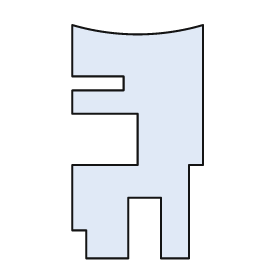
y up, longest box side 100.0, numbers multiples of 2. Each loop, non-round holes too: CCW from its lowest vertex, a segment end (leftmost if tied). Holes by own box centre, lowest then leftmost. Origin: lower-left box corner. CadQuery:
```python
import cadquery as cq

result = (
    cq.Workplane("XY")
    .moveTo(6.0, 0.0)
    .lineTo(24.0, 0.0)
    .lineTo(24.0, 26.0)
    .lineTo(38.0, 26.0)
    .lineTo(38.0, 0.0)
    .lineTo(50.0, 0.0)
    .lineTo(50.0, 40.0)
    .lineTo(56.0, 40.0)
    .lineTo(56.0, 100.0)
    .threePointArc((28.0, 96.0), (0.0, 100.0))
    .lineTo(0.0, 78.0)
    .lineTo(22.0, 78.0)
    .lineTo(22.0, 72.0)
    .lineTo(0.0, 72.0)
    .lineTo(0.0, 62.0)
    .lineTo(28.0, 62.0)
    .lineTo(28.0, 40.0)
    .lineTo(0.0, 40.0)
    .lineTo(0.0, 12.0)
    .lineTo(6.0, 12.0)
    .close()
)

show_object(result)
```